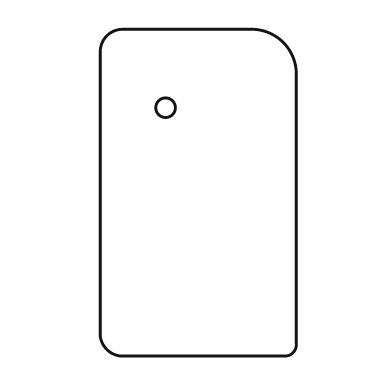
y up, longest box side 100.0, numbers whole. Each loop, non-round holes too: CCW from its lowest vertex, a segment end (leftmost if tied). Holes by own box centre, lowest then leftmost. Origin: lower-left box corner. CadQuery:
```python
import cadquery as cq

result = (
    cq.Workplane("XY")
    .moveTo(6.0, 0.0)
    .lineTo(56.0, 0.0)
    .threePointArc((59.0, 1.0), (60.0, 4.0))
    .lineTo(60.0, 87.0)
    .threePointArc((56.0, 96.0), (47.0, 100.0))
    .lineTo(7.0, 100.0)
    .threePointArc((2.0, 98.0), (0.0, 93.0))
    .lineTo(0.0, 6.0)
    .threePointArc((2.0, 2.0), (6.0, 0.0))
    .close()
    .moveTo(20.0, 76.0)
    .circle(3.0)
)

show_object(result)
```